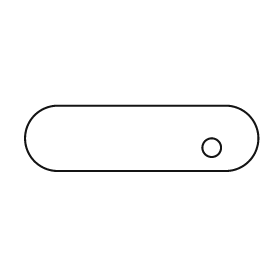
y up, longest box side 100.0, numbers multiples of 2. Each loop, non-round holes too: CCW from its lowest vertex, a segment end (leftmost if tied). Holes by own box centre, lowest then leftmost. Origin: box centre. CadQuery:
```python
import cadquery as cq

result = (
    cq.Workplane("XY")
    .moveTo(-36.0, -14.0)
    .lineTo(36.0, -14.0)
    .threePointArc((50.0, 0.0), (36.0, 14.0))
    .lineTo(-36.0, 14.0)
    .threePointArc((-50.0, 0.0), (-36.0, -14.0))
    .close()
    .moveTo(30.0, -4.0)
    .circle(4.0)
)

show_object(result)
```